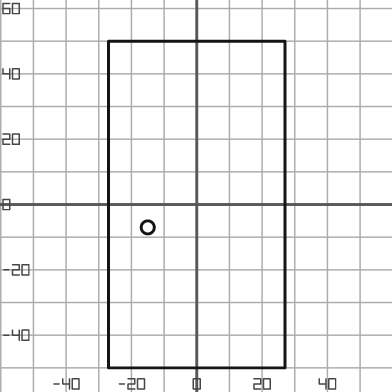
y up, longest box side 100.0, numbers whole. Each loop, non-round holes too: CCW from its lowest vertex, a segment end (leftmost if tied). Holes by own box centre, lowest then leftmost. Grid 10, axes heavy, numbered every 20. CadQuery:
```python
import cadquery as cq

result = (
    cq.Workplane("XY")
    .moveTo(-27.0, -50.0)
    .lineTo(27.0, -50.0)
    .lineTo(27.0, 50.0)
    .lineTo(-27.0, 50.0)
    .close()
    .moveTo(-15.0, -7.0)
    .circle(2.0)
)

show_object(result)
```